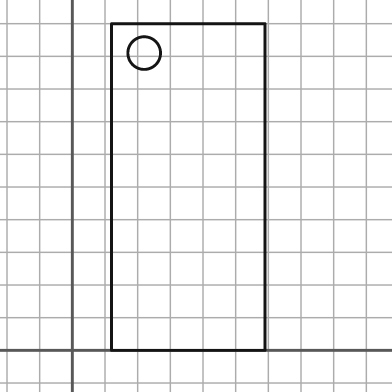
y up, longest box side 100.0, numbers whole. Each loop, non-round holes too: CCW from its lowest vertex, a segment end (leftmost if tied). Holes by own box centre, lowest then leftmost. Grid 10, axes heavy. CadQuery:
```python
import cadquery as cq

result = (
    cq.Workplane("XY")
    .moveTo(12.0, 0.0)
    .lineTo(59.0, 0.0)
    .lineTo(59.0, 100.0)
    .lineTo(12.0, 100.0)
    .close()
    .moveTo(22.0, 91.0)
    .circle(5.0)
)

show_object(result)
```